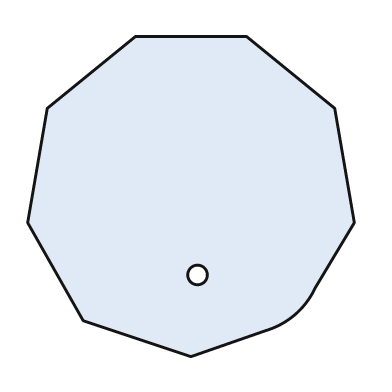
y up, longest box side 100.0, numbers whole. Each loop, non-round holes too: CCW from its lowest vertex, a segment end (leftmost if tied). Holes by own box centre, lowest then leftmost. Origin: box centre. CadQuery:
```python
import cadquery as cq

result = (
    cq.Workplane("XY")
    .moveTo(0.0, -49.0)
    .lineTo(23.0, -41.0)
    .threePointArc((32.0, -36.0), (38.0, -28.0))
    .lineTo(50.0, -8.0)
    .lineTo(44.0, 27.0)
    .lineTo(17.0, 49.0)
    .lineTo(-17.0, 49.0)
    .lineTo(-44.0, 27.0)
    .lineTo(-50.0, -8.0)
    .lineTo(-33.0, -38.0)
    .close()
    .moveTo(2.0, -24.0)
    .circle(3.0)
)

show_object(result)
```